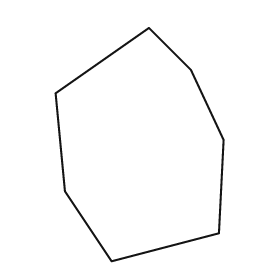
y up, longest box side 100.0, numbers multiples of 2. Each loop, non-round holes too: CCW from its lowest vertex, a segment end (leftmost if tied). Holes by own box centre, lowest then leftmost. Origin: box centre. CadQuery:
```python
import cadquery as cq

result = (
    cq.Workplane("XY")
    .moveTo(-12.0, -50.0)
    .lineTo(34.0, -38.0)
    .lineTo(36.0, 2.0)
    .lineTo(22.0, 32.0)
    .lineTo(4.0, 50.0)
    .lineTo(-36.0, 22.0)
    .lineTo(-32.0, -20.0)
    .close()
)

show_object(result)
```